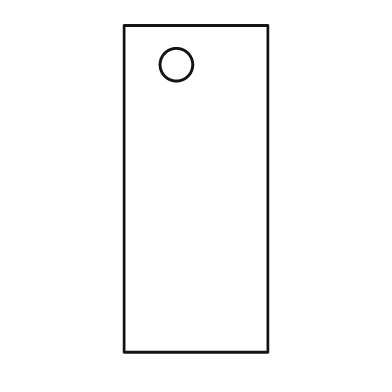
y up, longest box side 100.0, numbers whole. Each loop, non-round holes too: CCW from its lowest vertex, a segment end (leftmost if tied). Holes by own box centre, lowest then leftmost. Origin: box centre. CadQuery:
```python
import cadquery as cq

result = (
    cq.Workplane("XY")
    .moveTo(-22.0, -50.0)
    .lineTo(22.0, -50.0)
    .lineTo(22.0, 50.0)
    .lineTo(-22.0, 50.0)
    .close()
    .moveTo(-6.0, 38.0)
    .circle(5.0)
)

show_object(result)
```